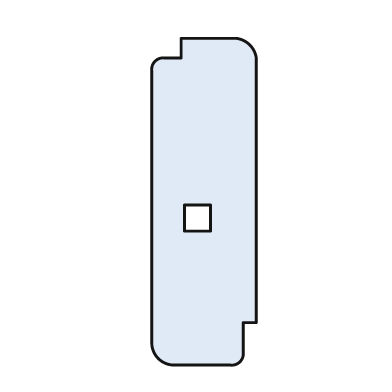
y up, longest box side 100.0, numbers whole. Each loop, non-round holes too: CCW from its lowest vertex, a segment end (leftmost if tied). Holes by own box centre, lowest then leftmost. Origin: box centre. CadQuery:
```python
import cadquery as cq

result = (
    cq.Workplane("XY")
    .moveTo(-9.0, -50.0)
    .lineTo(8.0, -50.0)
    .threePointArc((11.0, -49.0), (12.0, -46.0))
    .lineTo(12.0, -37.0)
    .lineTo(16.0, -37.0)
    .lineTo(16.0, 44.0)
    .threePointArc((14.0, 48.0), (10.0, 50.0))
    .lineTo(-7.0, 50.0)
    .lineTo(-7.0, 44.0)
    .lineTo(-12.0, 44.0)
    .threePointArc((-15.0, 43.0), (-16.0, 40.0))
    .lineTo(-16.0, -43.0)
    .threePointArc((-14.0, -48.0), (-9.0, -50.0))
    .close()
    .moveTo(-6.0, -9.0)
    .lineTo(2.0, -9.0)
    .lineTo(2.0, -1.0)
    .lineTo(-6.0, -1.0)
    .close()
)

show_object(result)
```